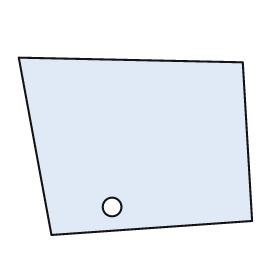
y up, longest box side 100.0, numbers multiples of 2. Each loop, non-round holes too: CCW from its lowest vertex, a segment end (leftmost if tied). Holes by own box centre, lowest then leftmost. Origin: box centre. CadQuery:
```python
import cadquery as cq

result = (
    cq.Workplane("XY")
    .moveTo(-36.0, -38.0)
    .lineTo(50.0, -32.0)
    .lineTo(46.0, 36.0)
    .lineTo(-50.0, 38.0)
    .close()
    .moveTo(-10.0, -26.0)
    .circle(4.0)
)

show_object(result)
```